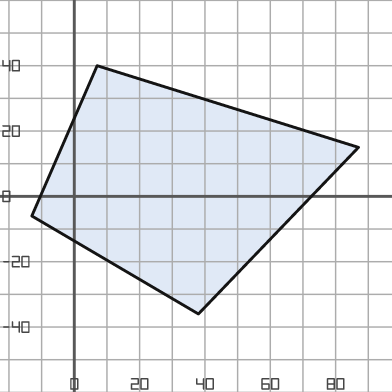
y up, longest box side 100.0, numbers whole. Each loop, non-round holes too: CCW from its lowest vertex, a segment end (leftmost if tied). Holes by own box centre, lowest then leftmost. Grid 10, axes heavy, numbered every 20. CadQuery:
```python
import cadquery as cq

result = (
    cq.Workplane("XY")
    .moveTo(38.0, -36.0)
    .lineTo(87.0, 15.0)
    .lineTo(7.0, 40.0)
    .lineTo(-13.0, -6.0)
    .close()
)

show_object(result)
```